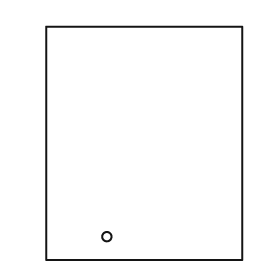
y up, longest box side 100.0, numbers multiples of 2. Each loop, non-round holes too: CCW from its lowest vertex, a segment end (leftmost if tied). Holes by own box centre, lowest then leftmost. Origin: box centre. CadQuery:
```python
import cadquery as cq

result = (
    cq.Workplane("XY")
    .moveTo(-42.0, -50.0)
    .lineTo(42.0, -50.0)
    .lineTo(42.0, 50.0)
    .lineTo(-42.0, 50.0)
    .close()
    .moveTo(-16.0, -40.0)
    .circle(2.0)
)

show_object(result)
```